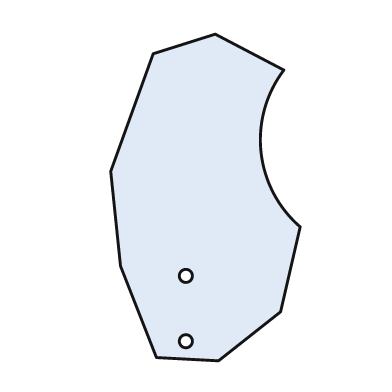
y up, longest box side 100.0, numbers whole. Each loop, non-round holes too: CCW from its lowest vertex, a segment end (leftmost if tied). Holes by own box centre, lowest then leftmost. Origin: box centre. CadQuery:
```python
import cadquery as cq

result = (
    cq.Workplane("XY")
    .moveTo(4.0, -50.0)
    .lineTo(23.0, -35.0)
    .lineTo(29.0, -9.0)
    .threePointArc((17.0, 14.0), (24.0, 39.0))
    .lineTo(3.0, 50.0)
    .lineTo(-16.0, 44.0)
    .lineTo(-29.0, 8.0)
    .lineTo(-26.0, -21.0)
    .lineTo(-15.0, -49.0)
    .close()
    .moveTo(-6.0, -44.0)
    .circle(2.0)
    .moveTo(-6.0, -24.0)
    .circle(2.0)
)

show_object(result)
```